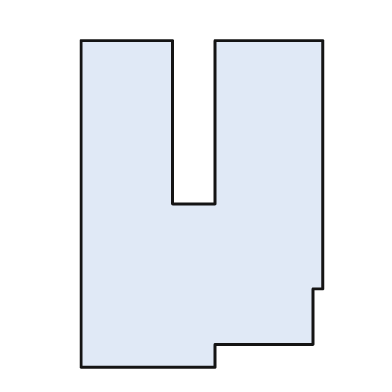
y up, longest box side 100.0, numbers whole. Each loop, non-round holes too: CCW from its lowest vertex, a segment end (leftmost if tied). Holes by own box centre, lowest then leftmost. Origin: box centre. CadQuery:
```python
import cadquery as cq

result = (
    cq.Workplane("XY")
    .moveTo(-37.0, -50.0)
    .lineTo(4.0, -50.0)
    .lineTo(4.0, -43.0)
    .lineTo(34.0, -43.0)
    .lineTo(34.0, -26.0)
    .lineTo(37.0, -26.0)
    .lineTo(37.0, 50.0)
    .lineTo(4.0, 50.0)
    .lineTo(4.0, 0.0)
    .lineTo(-9.0, 0.0)
    .lineTo(-9.0, 50.0)
    .lineTo(-37.0, 50.0)
    .close()
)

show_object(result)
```